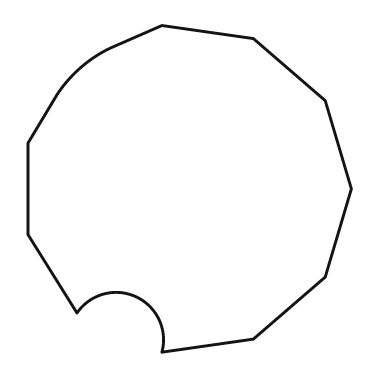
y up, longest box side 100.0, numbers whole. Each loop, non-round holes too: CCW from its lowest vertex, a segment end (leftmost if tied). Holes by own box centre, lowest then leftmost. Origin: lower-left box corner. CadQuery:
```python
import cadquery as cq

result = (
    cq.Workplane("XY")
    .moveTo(41.0, 0.0)
    .lineTo(69.0, 4.0)
    .lineTo(91.0, 23.0)
    .lineTo(99.0, 50.0)
    .lineTo(91.0, 77.0)
    .lineTo(69.0, 96.0)
    .lineTo(41.0, 100.0)
    .lineTo(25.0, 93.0)
    .threePointArc((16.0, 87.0), (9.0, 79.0))
    .lineTo(0.0, 64.0)
    .lineTo(0.0, 36.0)
    .lineTo(15.0, 12.0)
    .threePointArc((33.0, 17.0), (41.0, 0.0))
    .close()
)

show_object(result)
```